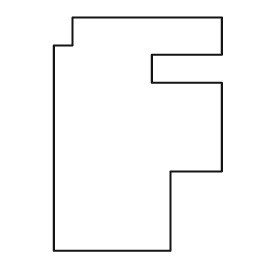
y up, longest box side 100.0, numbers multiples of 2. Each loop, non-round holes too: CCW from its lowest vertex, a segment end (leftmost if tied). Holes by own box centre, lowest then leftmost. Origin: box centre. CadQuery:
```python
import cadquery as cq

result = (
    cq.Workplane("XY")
    .moveTo(-36.0, -50.0)
    .lineTo(14.0, -50.0)
    .lineTo(14.0, -16.0)
    .lineTo(36.0, -16.0)
    .lineTo(36.0, 22.0)
    .lineTo(6.0, 22.0)
    .lineTo(6.0, 34.0)
    .lineTo(36.0, 34.0)
    .lineTo(36.0, 50.0)
    .lineTo(-28.0, 50.0)
    .lineTo(-28.0, 38.0)
    .lineTo(-36.0, 38.0)
    .close()
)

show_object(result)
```